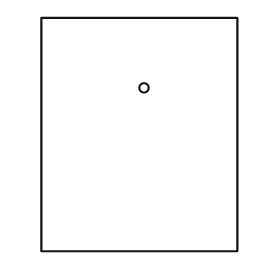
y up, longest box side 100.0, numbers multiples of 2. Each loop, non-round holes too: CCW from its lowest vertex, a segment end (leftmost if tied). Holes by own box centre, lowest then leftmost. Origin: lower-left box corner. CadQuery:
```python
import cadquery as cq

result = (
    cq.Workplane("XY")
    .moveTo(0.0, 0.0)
    .lineTo(84.0, 0.0)
    .lineTo(84.0, 100.0)
    .lineTo(0.0, 100.0)
    .close()
    .moveTo(44.0, 70.0)
    .circle(2.0)
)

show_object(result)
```